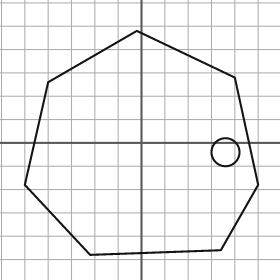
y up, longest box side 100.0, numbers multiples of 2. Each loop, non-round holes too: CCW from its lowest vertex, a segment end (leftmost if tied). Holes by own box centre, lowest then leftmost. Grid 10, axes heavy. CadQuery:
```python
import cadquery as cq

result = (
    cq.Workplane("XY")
    .moveTo(-22.0, -48.0)
    .lineTo(34.0, -46.0)
    .lineTo(50.0, -18.0)
    .lineTo(40.0, 28.0)
    .lineTo(-2.0, 48.0)
    .lineTo(-40.0, 26.0)
    .lineTo(-50.0, -18.0)
    .close()
    .moveTo(36.0, -4.0)
    .circle(6.0)
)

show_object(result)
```